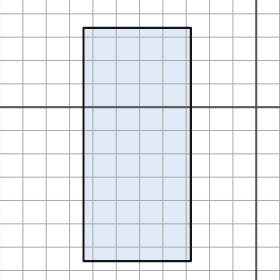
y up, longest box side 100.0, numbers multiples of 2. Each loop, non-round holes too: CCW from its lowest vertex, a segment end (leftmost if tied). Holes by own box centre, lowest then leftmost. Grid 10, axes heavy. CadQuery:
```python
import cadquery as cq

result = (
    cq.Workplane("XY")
    .moveTo(-74.0, -66.0)
    .lineTo(-28.0, -66.0)
    .lineTo(-28.0, 34.0)
    .lineTo(-74.0, 34.0)
    .close()
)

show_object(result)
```